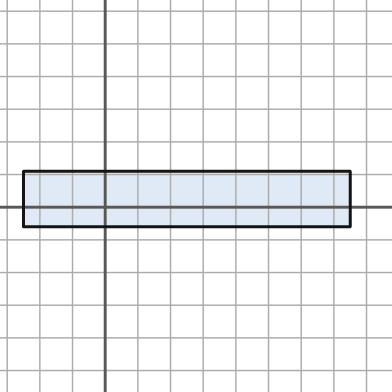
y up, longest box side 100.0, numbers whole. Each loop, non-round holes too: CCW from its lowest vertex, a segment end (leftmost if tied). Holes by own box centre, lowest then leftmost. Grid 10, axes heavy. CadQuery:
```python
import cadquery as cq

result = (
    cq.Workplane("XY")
    .moveTo(-25.0, -6.0)
    .lineTo(75.0, -6.0)
    .lineTo(75.0, 11.0)
    .lineTo(-25.0, 11.0)
    .close()
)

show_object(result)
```